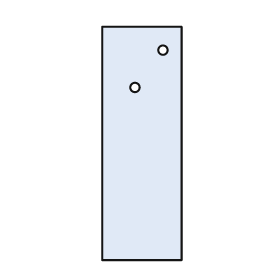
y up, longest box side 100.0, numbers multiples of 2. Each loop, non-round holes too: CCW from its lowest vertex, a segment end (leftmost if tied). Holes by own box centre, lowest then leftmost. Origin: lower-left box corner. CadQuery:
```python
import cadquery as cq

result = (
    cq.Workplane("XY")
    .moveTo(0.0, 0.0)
    .lineTo(34.0, 0.0)
    .lineTo(34.0, 100.0)
    .lineTo(0.0, 100.0)
    .close()
    .moveTo(14.0, 74.0)
    .circle(2.0)
    .moveTo(26.0, 90.0)
    .circle(2.0)
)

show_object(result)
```